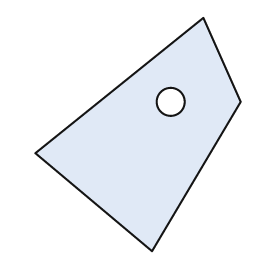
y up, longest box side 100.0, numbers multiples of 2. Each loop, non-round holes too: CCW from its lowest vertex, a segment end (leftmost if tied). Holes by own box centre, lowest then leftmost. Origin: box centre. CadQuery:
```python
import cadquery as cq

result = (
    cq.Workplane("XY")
    .moveTo(6.0, -50.0)
    .lineTo(44.0, 14.0)
    .lineTo(28.0, 50.0)
    .lineTo(-44.0, -8.0)
    .close()
    .moveTo(14.0, 14.0)
    .circle(6.0)
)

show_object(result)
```